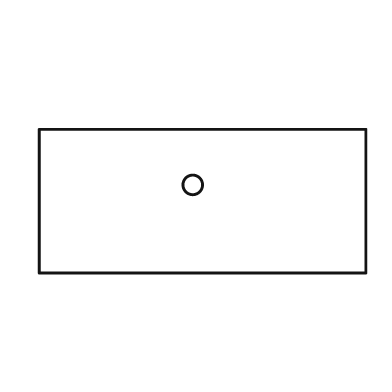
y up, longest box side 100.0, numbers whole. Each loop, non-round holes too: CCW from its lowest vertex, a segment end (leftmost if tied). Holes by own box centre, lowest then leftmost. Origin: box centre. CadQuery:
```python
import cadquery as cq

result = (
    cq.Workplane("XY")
    .moveTo(-50.0, -22.0)
    .lineTo(50.0, -22.0)
    .lineTo(50.0, 22.0)
    .lineTo(-50.0, 22.0)
    .close()
    .moveTo(-3.0, 5.0)
    .circle(3.0)
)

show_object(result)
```